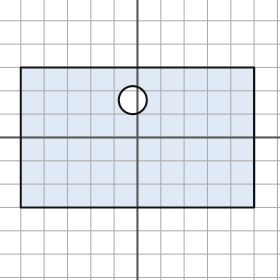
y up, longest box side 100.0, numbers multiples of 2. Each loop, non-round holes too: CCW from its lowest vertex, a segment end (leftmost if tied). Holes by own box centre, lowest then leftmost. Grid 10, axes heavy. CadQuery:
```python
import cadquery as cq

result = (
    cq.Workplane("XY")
    .moveTo(-50.0, -30.0)
    .lineTo(50.0, -30.0)
    .lineTo(50.0, 30.0)
    .lineTo(-50.0, 30.0)
    .close()
    .moveTo(-2.0, 16.0)
    .circle(6.0)
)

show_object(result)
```